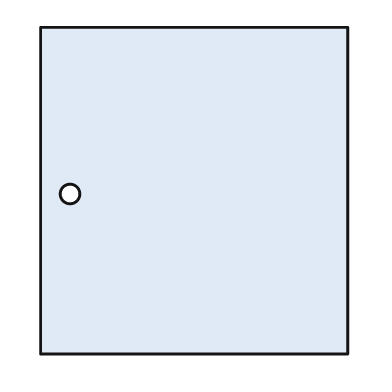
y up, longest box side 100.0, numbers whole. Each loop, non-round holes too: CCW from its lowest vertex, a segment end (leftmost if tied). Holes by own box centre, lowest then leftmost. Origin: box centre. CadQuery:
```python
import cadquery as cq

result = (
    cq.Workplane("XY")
    .moveTo(-47.0, -50.0)
    .lineTo(47.0, -50.0)
    .lineTo(47.0, 50.0)
    .lineTo(-47.0, 50.0)
    .close()
    .moveTo(-38.0, -1.0)
    .circle(3.0)
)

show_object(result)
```